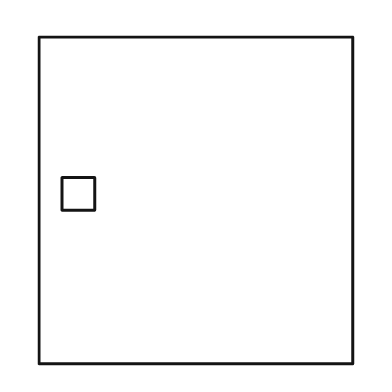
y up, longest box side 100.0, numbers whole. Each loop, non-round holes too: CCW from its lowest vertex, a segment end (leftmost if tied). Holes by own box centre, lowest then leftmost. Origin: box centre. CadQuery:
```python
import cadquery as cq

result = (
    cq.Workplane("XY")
    .moveTo(-48.0, -50.0)
    .lineTo(48.0, -50.0)
    .lineTo(48.0, 50.0)
    .lineTo(-48.0, 50.0)
    .close()
    .moveTo(-41.0, -3.0)
    .lineTo(-31.0, -3.0)
    .lineTo(-31.0, 7.0)
    .lineTo(-41.0, 7.0)
    .close()
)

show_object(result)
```